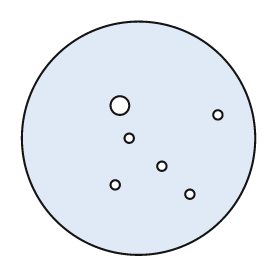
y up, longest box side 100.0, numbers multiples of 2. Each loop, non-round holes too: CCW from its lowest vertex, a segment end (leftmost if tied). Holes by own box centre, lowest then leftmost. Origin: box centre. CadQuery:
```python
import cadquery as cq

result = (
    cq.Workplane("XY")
    .moveTo(0.0, 0.0)
    .circle(50.0)
    .moveTo(22.0, -24.0)
    .circle(2.0)
    .moveTo(-10.0, -20.0)
    .circle(2.0)
    .moveTo(10.0, -12.0)
    .circle(2.0)
    .moveTo(-4.0, 0.0)
    .circle(2.0)
    .moveTo(34.0, 10.0)
    .circle(2.0)
    .moveTo(-8.0, 14.0)
    .circle(4.0)
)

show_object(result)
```